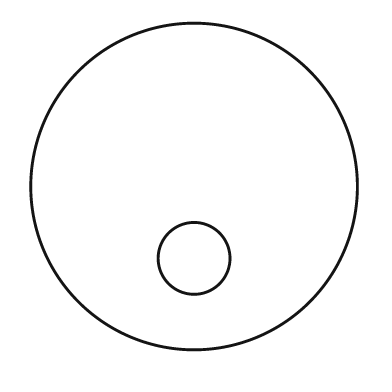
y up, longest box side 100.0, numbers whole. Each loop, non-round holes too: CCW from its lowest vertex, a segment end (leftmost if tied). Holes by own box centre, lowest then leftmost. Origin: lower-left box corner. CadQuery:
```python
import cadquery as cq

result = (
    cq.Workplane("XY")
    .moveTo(50.0, 50.0)
    .circle(50.0)
    .moveTo(50.0, 28.0)
    .circle(11.0)
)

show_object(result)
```